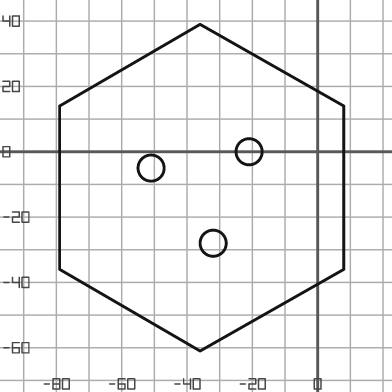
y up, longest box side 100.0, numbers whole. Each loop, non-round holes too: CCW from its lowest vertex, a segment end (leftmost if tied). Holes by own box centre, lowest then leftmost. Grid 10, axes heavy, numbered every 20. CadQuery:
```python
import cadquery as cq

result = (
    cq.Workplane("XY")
    .moveTo(-36.0, -61.0)
    .lineTo(8.0, -36.0)
    .lineTo(8.0, 14.0)
    .lineTo(-36.0, 39.0)
    .lineTo(-79.0, 14.0)
    .lineTo(-79.0, -36.0)
    .close()
    .moveTo(-32.0, -28.0)
    .circle(4.0)
    .moveTo(-51.0, -5.0)
    .circle(4.0)
    .moveTo(-21.0, 0.0)
    .circle(4.0)
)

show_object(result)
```